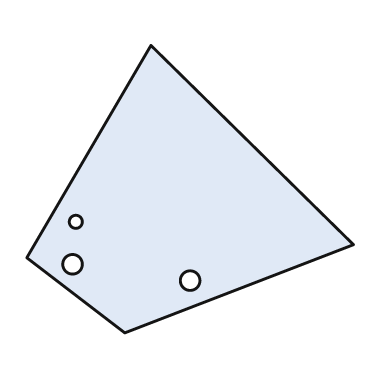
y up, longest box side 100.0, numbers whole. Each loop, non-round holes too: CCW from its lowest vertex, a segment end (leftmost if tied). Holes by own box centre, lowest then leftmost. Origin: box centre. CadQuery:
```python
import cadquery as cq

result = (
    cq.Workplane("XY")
    .moveTo(-20.0, -44.0)
    .lineTo(50.0, -17.0)
    .lineTo(-12.0, 44.0)
    .lineTo(-50.0, -21.0)
    .close()
    .moveTo(0.0, -28.0)
    .circle(3.0)
    .moveTo(-36.0, -23.0)
    .circle(3.0)
    .moveTo(-35.0, -10.0)
    .circle(2.0)
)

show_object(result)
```